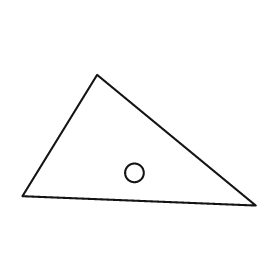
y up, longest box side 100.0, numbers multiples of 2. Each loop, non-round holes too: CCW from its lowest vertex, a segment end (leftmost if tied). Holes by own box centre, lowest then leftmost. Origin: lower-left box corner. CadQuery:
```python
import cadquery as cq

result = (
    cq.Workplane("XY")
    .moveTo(100.0, 0.0)
    .lineTo(32.0, 56.0)
    .lineTo(0.0, 4.0)
    .close()
    .moveTo(48.0, 14.0)
    .circle(4.0)
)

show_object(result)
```